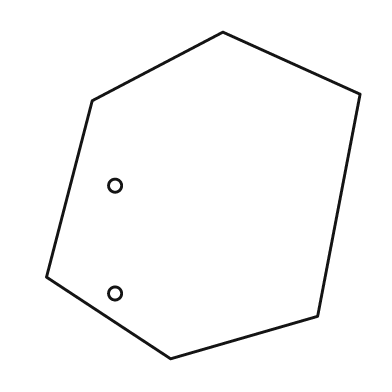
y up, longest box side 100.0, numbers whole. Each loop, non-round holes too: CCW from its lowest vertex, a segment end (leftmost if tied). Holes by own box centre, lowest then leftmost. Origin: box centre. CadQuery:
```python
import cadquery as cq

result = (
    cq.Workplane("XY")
    .moveTo(-10.0, -50.0)
    .lineTo(35.0, -37.0)
    .lineTo(48.0, 31.0)
    .lineTo(6.0, 50.0)
    .lineTo(-34.0, 29.0)
    .lineTo(-48.0, -25.0)
    .close()
    .moveTo(-27.0, -30.0)
    .circle(2.0)
    .moveTo(-27.0, 3.0)
    .circle(2.0)
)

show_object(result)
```